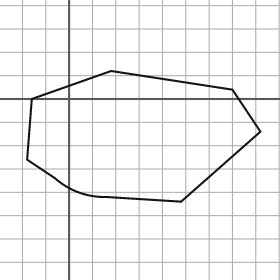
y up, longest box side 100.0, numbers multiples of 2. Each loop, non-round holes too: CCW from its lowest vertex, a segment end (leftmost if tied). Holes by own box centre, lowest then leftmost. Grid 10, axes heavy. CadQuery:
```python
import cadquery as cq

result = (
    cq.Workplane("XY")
    .moveTo(48.0, -44.0)
    .lineTo(82.0, -14.0)
    .lineTo(70.0, 4.0)
    .lineTo(18.0, 12.0)
    .lineTo(-16.0, 0.0)
    .lineTo(-18.0, -26.0)
    .lineTo(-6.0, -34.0)
    .threePointArc((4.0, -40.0), (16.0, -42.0))
    .close()
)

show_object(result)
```